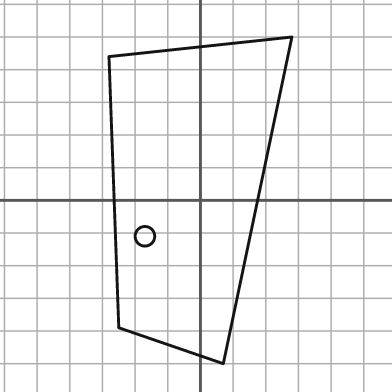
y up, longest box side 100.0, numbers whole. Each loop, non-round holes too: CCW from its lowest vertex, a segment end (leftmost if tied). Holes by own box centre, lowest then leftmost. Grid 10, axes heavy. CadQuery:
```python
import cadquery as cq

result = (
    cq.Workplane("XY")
    .moveTo(7.0, -50.0)
    .lineTo(28.0, 50.0)
    .lineTo(-28.0, 44.0)
    .lineTo(-25.0, -39.0)
    .close()
    .moveTo(-17.0, -11.0)
    .circle(3.0)
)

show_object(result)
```